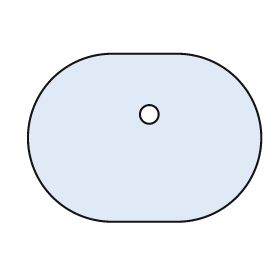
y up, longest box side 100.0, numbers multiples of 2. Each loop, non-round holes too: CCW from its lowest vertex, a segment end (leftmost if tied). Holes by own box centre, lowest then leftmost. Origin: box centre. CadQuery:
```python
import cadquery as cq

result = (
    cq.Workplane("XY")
    .moveTo(-14.0, -36.0)
    .lineTo(14.0, -36.0)
    .threePointArc((50.0, 0.0), (14.0, 36.0))
    .lineTo(-14.0, 36.0)
    .threePointArc((-50.0, 0.0), (-14.0, -36.0))
    .close()
    .moveTo(2.0, 10.0)
    .circle(4.0)
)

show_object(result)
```